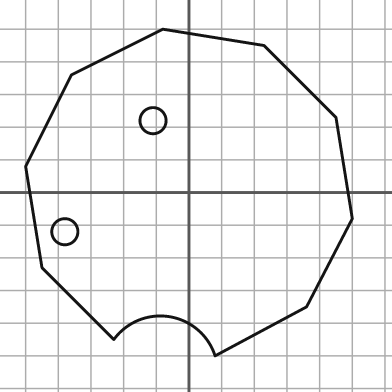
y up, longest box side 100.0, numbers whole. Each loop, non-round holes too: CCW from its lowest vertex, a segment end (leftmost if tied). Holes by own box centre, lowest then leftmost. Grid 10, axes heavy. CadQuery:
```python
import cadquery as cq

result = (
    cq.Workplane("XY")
    .moveTo(8.0, -50.0)
    .lineTo(36.0, -35.0)
    .lineTo(50.0, -8.0)
    .lineTo(45.0, 23.0)
    .lineTo(23.0, 45.0)
    .lineTo(-8.0, 50.0)
    .lineTo(-36.0, 36.0)
    .lineTo(-50.0, 8.0)
    .lineTo(-45.0, -23.0)
    .lineTo(-23.0, -45.0)
    .threePointArc((-6.0, -38.0), (8.0, -50.0))
    .close()
    .moveTo(-38.0, -12.0)
    .circle(4.0)
    .moveTo(-11.0, 22.0)
    .circle(4.0)
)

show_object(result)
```